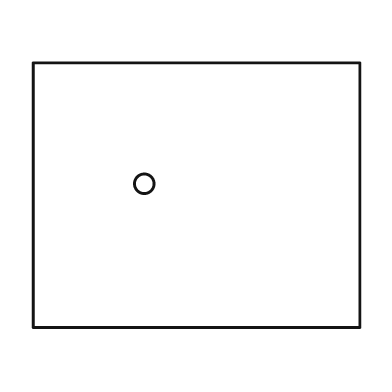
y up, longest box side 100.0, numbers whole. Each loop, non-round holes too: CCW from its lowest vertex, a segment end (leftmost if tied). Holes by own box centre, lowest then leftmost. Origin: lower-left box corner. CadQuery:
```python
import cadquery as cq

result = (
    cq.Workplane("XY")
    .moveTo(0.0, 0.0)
    .lineTo(100.0, 0.0)
    .lineTo(100.0, 81.0)
    .lineTo(0.0, 81.0)
    .close()
    .moveTo(34.0, 44.0)
    .circle(3.0)
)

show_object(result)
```